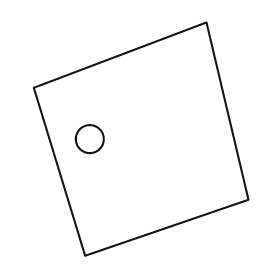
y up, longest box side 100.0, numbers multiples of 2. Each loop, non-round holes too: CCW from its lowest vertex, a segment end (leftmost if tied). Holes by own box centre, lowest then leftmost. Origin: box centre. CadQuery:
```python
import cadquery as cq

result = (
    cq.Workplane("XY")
    .moveTo(-24.0, -50.0)
    .lineTo(46.0, -26.0)
    .lineTo(28.0, 50.0)
    .lineTo(-46.0, 22.0)
    .close()
    .moveTo(-22.0, 0.0)
    .circle(6.0)
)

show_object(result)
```